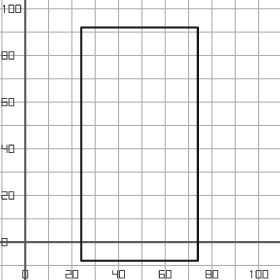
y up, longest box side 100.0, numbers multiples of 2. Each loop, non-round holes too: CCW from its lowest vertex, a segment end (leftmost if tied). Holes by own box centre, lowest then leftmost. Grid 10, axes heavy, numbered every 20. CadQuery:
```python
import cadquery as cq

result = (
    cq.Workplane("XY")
    .moveTo(24.0, -8.0)
    .lineTo(74.0, -8.0)
    .lineTo(74.0, 92.0)
    .lineTo(24.0, 92.0)
    .close()
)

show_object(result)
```